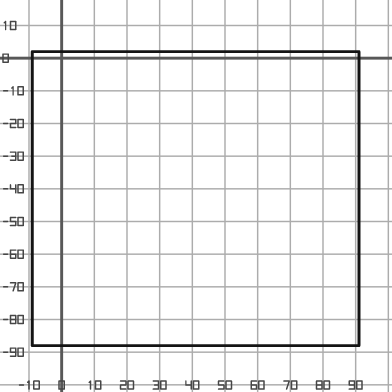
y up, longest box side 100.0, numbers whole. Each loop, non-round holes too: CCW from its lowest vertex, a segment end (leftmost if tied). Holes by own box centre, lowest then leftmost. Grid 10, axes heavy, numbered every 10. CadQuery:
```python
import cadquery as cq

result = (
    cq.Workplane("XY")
    .moveTo(-9.0, -88.0)
    .lineTo(91.0, -88.0)
    .lineTo(91.0, 2.0)
    .lineTo(-9.0, 2.0)
    .close()
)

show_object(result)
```